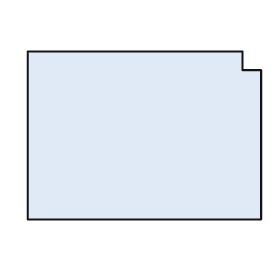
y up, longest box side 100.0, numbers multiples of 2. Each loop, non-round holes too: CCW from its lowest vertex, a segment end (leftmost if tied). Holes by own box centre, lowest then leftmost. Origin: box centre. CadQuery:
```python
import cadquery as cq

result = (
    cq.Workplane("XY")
    .moveTo(-50.0, -36.0)
    .lineTo(50.0, -36.0)
    .lineTo(50.0, 28.0)
    .lineTo(42.0, 28.0)
    .lineTo(42.0, 36.0)
    .lineTo(-50.0, 36.0)
    .close()
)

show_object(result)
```